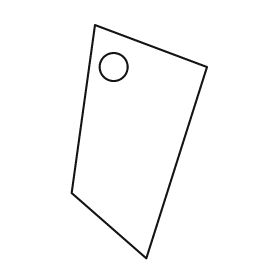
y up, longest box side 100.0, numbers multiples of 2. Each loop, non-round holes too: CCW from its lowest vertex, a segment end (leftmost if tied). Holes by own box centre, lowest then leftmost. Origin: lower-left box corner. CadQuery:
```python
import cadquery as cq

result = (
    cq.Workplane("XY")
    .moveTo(32.0, 0.0)
    .lineTo(58.0, 82.0)
    .lineTo(10.0, 100.0)
    .lineTo(0.0, 28.0)
    .close()
    .moveTo(18.0, 82.0)
    .circle(6.0)
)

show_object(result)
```